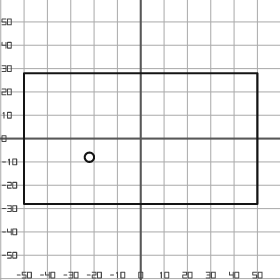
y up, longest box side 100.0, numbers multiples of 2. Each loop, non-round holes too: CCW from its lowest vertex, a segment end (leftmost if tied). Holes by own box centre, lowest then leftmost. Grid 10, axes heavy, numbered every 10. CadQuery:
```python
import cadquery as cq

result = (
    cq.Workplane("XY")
    .moveTo(-50.0, -28.0)
    .lineTo(50.0, -28.0)
    .lineTo(50.0, 28.0)
    .lineTo(-50.0, 28.0)
    .close()
    .moveTo(-22.0, -8.0)
    .circle(2.0)
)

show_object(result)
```